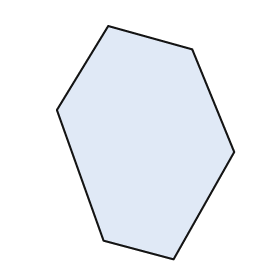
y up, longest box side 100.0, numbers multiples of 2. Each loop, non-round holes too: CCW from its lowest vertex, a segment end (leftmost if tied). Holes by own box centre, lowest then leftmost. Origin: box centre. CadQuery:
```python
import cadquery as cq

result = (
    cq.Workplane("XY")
    .moveTo(12.0, -50.0)
    .lineTo(38.0, -4.0)
    .lineTo(20.0, 40.0)
    .lineTo(-16.0, 50.0)
    .lineTo(-38.0, 14.0)
    .lineTo(-18.0, -42.0)
    .close()
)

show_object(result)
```